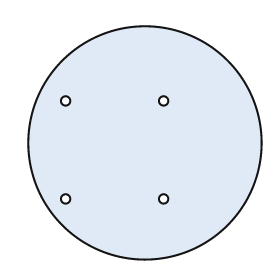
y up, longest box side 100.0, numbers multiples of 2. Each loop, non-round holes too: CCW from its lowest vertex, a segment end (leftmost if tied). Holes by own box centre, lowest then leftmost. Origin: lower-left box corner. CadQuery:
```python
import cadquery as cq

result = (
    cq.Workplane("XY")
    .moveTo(50.0, 50.0)
    .circle(50.0)
    .moveTo(16.0, 26.0)
    .circle(2.0)
    .moveTo(58.0, 26.0)
    .circle(2.0)
    .moveTo(16.0, 68.0)
    .circle(2.0)
    .moveTo(58.0, 68.0)
    .circle(2.0)
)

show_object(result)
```